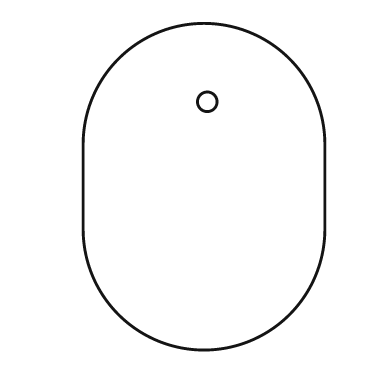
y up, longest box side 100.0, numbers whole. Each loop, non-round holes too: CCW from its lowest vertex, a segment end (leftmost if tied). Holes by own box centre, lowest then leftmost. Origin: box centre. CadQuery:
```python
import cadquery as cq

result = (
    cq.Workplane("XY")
    .moveTo(-37.0, -13.0)
    .threePointArc((0.0, -50.0), (37.0, -13.0))
    .lineTo(37.0, 13.0)
    .threePointArc((0.0, 50.0), (-37.0, 13.0))
    .close()
    .moveTo(1.0, 26.0)
    .circle(3.0)
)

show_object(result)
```